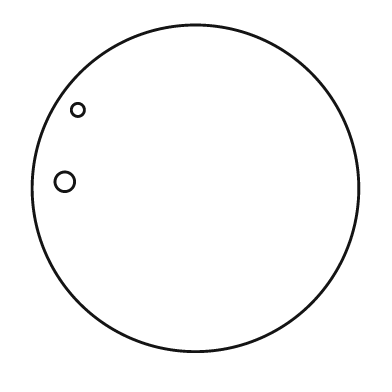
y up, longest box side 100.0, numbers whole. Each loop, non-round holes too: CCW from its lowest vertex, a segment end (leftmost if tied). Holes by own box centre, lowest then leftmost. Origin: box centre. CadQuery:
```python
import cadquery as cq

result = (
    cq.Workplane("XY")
    .moveTo(0.0, 0.0)
    .circle(50.0)
    .moveTo(-40.0, 2.0)
    .circle(3.0)
    .moveTo(-36.0, 24.0)
    .circle(2.0)
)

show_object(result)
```